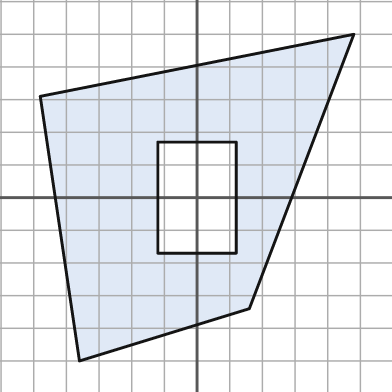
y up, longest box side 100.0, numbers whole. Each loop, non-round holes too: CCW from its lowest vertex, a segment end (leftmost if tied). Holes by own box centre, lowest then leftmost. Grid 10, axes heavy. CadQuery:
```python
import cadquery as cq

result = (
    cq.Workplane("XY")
    .moveTo(-36.0, -50.0)
    .lineTo(16.0, -34.0)
    .lineTo(48.0, 50.0)
    .lineTo(-48.0, 31.0)
    .close()
    .moveTo(-12.0, -17.0)
    .lineTo(12.0, -17.0)
    .lineTo(12.0, 17.0)
    .lineTo(-12.0, 17.0)
    .close()
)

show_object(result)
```